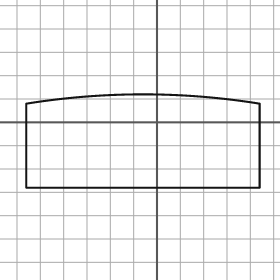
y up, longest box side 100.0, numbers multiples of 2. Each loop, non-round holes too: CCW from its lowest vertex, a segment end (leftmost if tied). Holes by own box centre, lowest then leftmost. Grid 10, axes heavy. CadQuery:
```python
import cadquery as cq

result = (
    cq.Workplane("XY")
    .moveTo(-56.0, -28.0)
    .lineTo(44.0, -28.0)
    .lineTo(44.0, 8.0)
    .threePointArc((-6.0, 12.0), (-56.0, 8.0))
    .close()
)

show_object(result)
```